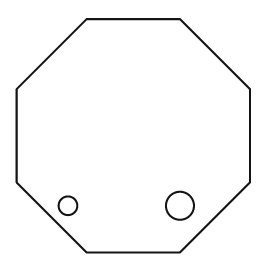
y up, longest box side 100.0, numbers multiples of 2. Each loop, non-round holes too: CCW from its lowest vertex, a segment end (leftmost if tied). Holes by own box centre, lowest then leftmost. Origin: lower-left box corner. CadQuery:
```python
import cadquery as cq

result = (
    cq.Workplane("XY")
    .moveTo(30.0, 0.0)
    .lineTo(70.0, 0.0)
    .lineTo(100.0, 30.0)
    .lineTo(100.0, 70.0)
    .lineTo(70.0, 100.0)
    .lineTo(30.0, 100.0)
    .lineTo(0.0, 70.0)
    .lineTo(0.0, 30.0)
    .close()
    .moveTo(22.0, 20.0)
    .circle(4.0)
    .moveTo(70.0, 20.0)
    .circle(6.0)
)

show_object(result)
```